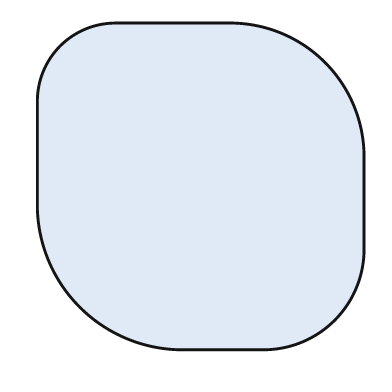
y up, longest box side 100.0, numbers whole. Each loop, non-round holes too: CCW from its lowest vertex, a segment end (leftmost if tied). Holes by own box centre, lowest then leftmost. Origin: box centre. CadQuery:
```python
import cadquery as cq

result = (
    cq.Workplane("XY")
    .moveTo(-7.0, -50.0)
    .lineTo(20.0, -50.0)
    .threePointArc((41.0, -41.0), (50.0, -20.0))
    .lineTo(50.0, 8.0)
    .threePointArc((38.0, 38.0), (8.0, 50.0))
    .lineTo(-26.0, 50.0)
    .threePointArc((-43.0, 43.0), (-50.0, 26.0))
    .lineTo(-50.0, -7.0)
    .threePointArc((-37.0, -37.0), (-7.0, -50.0))
    .close()
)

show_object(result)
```